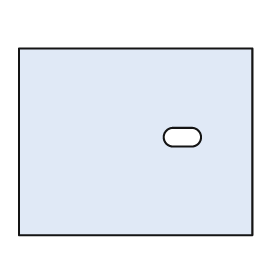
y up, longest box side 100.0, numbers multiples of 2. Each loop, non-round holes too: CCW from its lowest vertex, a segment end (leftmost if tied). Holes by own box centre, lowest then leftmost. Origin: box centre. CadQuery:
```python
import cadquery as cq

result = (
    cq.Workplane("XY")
    .moveTo(-50.0, -40.0)
    .lineTo(50.0, -40.0)
    .lineTo(50.0, 40.0)
    .lineTo(-50.0, 40.0)
    .close()
    .moveTo(16.0, -2.0)
    .lineTo(24.0, -2.0)
    .threePointArc((28.0, 2.0), (24.0, 6.0))
    .lineTo(16.0, 6.0)
    .threePointArc((12.0, 2.0), (16.0, -2.0))
    .close()
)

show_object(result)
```